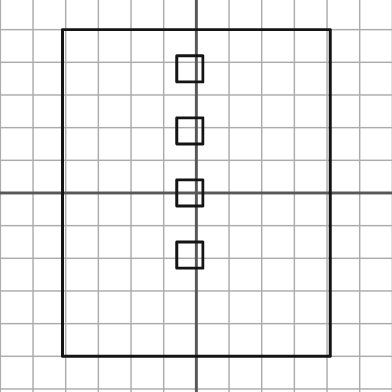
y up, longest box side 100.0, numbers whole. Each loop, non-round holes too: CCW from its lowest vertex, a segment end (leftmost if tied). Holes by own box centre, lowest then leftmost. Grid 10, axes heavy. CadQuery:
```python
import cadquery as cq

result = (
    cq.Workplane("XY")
    .moveTo(-41.0, -50.0)
    .lineTo(41.0, -50.0)
    .lineTo(41.0, 50.0)
    .lineTo(-41.0, 50.0)
    .close()
    .moveTo(-6.0, -23.0)
    .lineTo(2.0, -23.0)
    .lineTo(2.0, -15.0)
    .lineTo(-6.0, -15.0)
    .close()
    .moveTo(-6.0, -4.0)
    .lineTo(2.0, -4.0)
    .lineTo(2.0, 4.0)
    .lineTo(-6.0, 4.0)
    .close()
    .moveTo(-6.0, 15.0)
    .lineTo(2.0, 15.0)
    .lineTo(2.0, 23.0)
    .lineTo(-6.0, 23.0)
    .close()
    .moveTo(-6.0, 34.0)
    .lineTo(2.0, 34.0)
    .lineTo(2.0, 42.0)
    .lineTo(-6.0, 42.0)
    .close()
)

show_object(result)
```